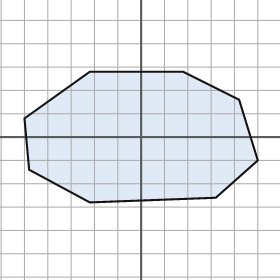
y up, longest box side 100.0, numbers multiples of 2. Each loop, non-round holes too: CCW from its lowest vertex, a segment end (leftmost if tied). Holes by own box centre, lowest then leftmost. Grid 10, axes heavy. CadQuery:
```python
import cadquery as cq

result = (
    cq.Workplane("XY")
    .moveTo(-22.0, -28.0)
    .lineTo(32.0, -26.0)
    .lineTo(50.0, -10.0)
    .lineTo(42.0, 16.0)
    .lineTo(18.0, 28.0)
    .lineTo(-22.0, 28.0)
    .lineTo(-50.0, 8.0)
    .lineTo(-48.0, -14.0)
    .close()
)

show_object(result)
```